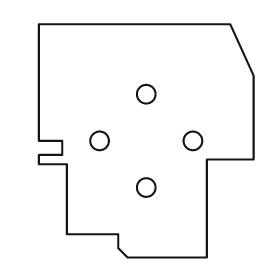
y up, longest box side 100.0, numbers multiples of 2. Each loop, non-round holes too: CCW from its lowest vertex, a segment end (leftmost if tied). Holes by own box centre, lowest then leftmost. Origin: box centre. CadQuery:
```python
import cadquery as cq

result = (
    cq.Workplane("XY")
    .moveTo(-8.0, -50.0)
    .lineTo(26.0, -50.0)
    .lineTo(26.0, -8.0)
    .lineTo(46.0, -8.0)
    .lineTo(46.0, 28.0)
    .lineTo(36.0, 50.0)
    .lineTo(-46.0, 50.0)
    .lineTo(-46.0, 0.0)
    .lineTo(-36.0, 0.0)
    .lineTo(-36.0, -6.0)
    .lineTo(-46.0, -6.0)
    .lineTo(-46.0, -10.0)
    .lineTo(-34.0, -10.0)
    .lineTo(-34.0, -40.0)
    .lineTo(-12.0, -40.0)
    .lineTo(-12.0, -46.0)
    .close()
    .moveTo(0.0, -20.0)
    .circle(4.0)
    .moveTo(-20.0, 0.0)
    .circle(4.0)
    .moveTo(20.0, 0.0)
    .circle(4.0)
    .moveTo(0.0, 20.0)
    .circle(4.0)
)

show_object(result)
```